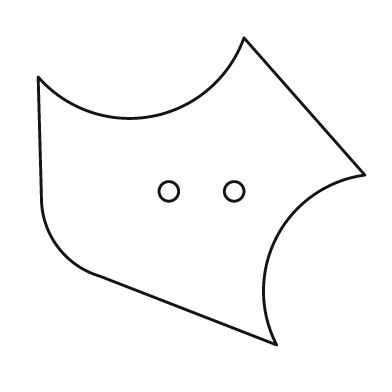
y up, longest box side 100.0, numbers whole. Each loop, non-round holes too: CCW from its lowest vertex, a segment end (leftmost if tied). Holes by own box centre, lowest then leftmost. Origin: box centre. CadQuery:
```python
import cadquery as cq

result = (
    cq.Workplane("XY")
    .moveTo(23.0, -47.0)
    .threePointArc((23.0, -14.0), (50.0, 5.0))
    .lineTo(13.0, 47.0)
    .threePointArc((-15.0, 23.0), (-50.0, 35.0))
    .lineTo(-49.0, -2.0)
    .threePointArc((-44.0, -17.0), (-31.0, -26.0))
    .close()
    .moveTo(-10.0, 0.0)
    .circle(3.0)
    .moveTo(10.0, 0.0)
    .circle(3.0)
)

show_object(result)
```